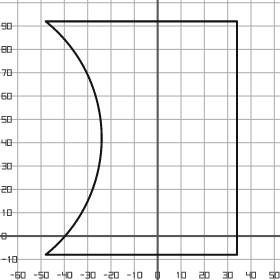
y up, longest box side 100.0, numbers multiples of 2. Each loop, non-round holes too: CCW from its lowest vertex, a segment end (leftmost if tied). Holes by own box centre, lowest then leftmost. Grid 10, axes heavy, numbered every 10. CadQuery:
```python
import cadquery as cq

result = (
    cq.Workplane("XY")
    .moveTo(-48.0, -8.0)
    .lineTo(34.0, -8.0)
    .lineTo(34.0, 92.0)
    .lineTo(-48.0, 92.0)
    .threePointArc((-24.0, 42.0), (-48.0, -8.0))
    .close()
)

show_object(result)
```